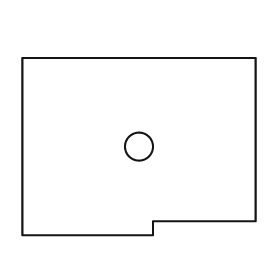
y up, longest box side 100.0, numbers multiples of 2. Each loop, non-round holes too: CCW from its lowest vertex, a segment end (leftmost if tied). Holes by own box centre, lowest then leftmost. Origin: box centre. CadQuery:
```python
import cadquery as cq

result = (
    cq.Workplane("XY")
    .moveTo(-50.0, -38.0)
    .lineTo(6.0, -38.0)
    .lineTo(6.0, -32.0)
    .lineTo(50.0, -32.0)
    .lineTo(50.0, 38.0)
    .lineTo(-50.0, 38.0)
    .close()
    .moveTo(0.0, 0.0)
    .circle(6.0)
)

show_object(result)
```